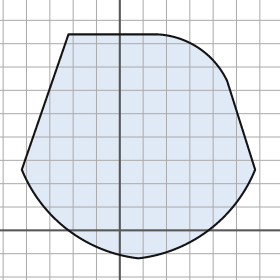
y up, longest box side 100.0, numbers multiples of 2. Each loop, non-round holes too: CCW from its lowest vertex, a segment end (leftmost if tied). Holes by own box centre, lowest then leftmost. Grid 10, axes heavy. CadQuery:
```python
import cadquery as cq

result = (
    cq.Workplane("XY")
    .moveTo(8.0, -12.0)
    .threePointArc((38.0, 0.0), (58.0, 26.0))
    .lineTo(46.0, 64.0)
    .threePointArc((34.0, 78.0), (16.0, 84.0))
    .lineTo(-22.0, 84.0)
    .lineTo(-42.0, 26.0)
    .threePointArc((-22.0, 0.0), (8.0, -12.0))
    .close()
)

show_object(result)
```